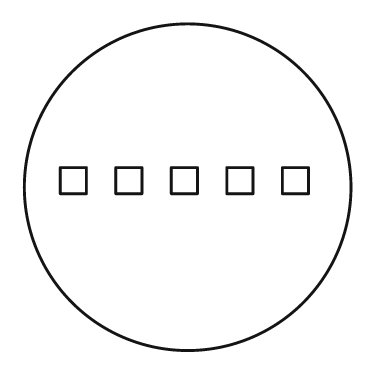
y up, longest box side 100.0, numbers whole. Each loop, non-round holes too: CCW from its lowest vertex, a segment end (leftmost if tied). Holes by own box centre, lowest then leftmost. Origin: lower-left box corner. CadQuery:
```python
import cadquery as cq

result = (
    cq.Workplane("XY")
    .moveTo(50.0, 50.0)
    .circle(50.0)
    .moveTo(11.0, 48.0)
    .lineTo(19.0, 48.0)
    .lineTo(19.0, 56.0)
    .lineTo(11.0, 56.0)
    .close()
    .moveTo(28.0, 48.0)
    .lineTo(36.0, 48.0)
    .lineTo(36.0, 56.0)
    .lineTo(28.0, 56.0)
    .close()
    .moveTo(45.0, 48.0)
    .lineTo(53.0, 48.0)
    .lineTo(53.0, 56.0)
    .lineTo(45.0, 56.0)
    .close()
    .moveTo(62.0, 48.0)
    .lineTo(70.0, 48.0)
    .lineTo(70.0, 56.0)
    .lineTo(62.0, 56.0)
    .close()
    .moveTo(79.0, 48.0)
    .lineTo(87.0, 48.0)
    .lineTo(87.0, 56.0)
    .lineTo(79.0, 56.0)
    .close()
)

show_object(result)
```